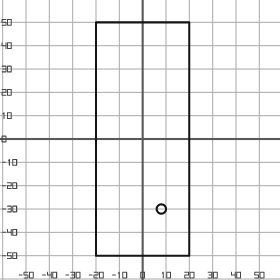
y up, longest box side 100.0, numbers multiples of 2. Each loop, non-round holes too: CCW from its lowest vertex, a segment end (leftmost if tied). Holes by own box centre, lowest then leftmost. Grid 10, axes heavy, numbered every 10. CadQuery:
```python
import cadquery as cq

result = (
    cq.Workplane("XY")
    .moveTo(-20.0, -50.0)
    .lineTo(20.0, -50.0)
    .lineTo(20.0, 50.0)
    .lineTo(-20.0, 50.0)
    .close()
    .moveTo(8.0, -30.0)
    .circle(2.0)
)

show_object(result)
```